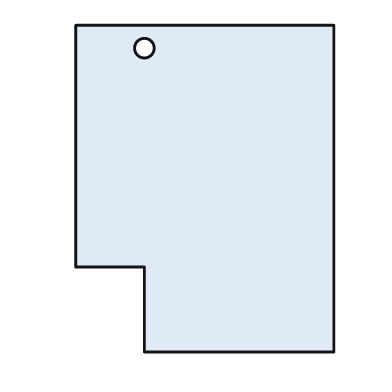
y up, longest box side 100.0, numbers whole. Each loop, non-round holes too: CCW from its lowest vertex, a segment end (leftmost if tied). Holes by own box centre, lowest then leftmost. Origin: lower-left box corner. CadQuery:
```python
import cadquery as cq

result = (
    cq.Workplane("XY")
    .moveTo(21.0, 0.0)
    .lineTo(79.0, 0.0)
    .lineTo(79.0, 100.0)
    .lineTo(0.0, 100.0)
    .lineTo(0.0, 26.0)
    .lineTo(21.0, 26.0)
    .close()
    .moveTo(21.0, 93.0)
    .circle(3.0)
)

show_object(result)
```